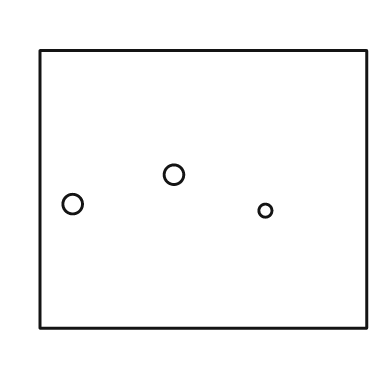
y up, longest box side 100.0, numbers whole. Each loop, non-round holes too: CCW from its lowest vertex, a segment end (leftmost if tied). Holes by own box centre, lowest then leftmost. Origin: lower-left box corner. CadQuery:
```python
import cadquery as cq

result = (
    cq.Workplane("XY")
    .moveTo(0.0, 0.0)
    .lineTo(100.0, 0.0)
    .lineTo(100.0, 85.0)
    .lineTo(0.0, 85.0)
    .close()
    .moveTo(69.0, 36.0)
    .circle(2.0)
    .moveTo(10.0, 38.0)
    .circle(3.0)
    .moveTo(41.0, 47.0)
    .circle(3.0)
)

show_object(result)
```